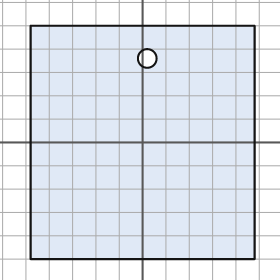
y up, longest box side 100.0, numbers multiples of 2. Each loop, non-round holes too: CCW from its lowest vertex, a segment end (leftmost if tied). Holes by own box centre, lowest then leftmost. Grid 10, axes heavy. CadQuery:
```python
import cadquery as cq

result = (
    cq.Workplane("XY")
    .moveTo(-48.0, -50.0)
    .lineTo(48.0, -50.0)
    .lineTo(48.0, 50.0)
    .lineTo(-48.0, 50.0)
    .close()
    .moveTo(2.0, 36.0)
    .circle(4.0)
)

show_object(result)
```